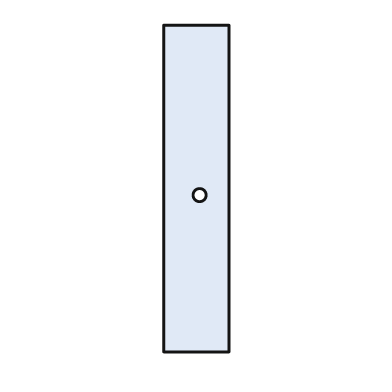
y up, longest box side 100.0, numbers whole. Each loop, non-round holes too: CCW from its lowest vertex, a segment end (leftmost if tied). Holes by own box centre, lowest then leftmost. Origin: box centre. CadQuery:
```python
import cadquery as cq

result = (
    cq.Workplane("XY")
    .moveTo(-10.0, -50.0)
    .lineTo(10.0, -50.0)
    .lineTo(10.0, 50.0)
    .lineTo(-10.0, 50.0)
    .close()
    .moveTo(1.0, -2.0)
    .circle(2.0)
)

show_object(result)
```